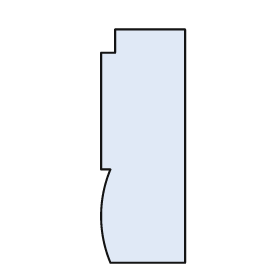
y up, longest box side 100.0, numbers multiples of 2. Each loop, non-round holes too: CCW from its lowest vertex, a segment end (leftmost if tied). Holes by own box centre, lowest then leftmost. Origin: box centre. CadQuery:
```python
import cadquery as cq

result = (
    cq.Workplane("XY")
    .moveTo(-14.0, -50.0)
    .lineTo(18.0, -50.0)
    .lineTo(18.0, 50.0)
    .lineTo(-12.0, 50.0)
    .lineTo(-12.0, 40.0)
    .lineTo(-18.0, 40.0)
    .lineTo(-18.0, -10.0)
    .lineTo(-14.0, -10.0)
    .threePointArc((-18.0, -30.0), (-14.0, -50.0))
    .close()
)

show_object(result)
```